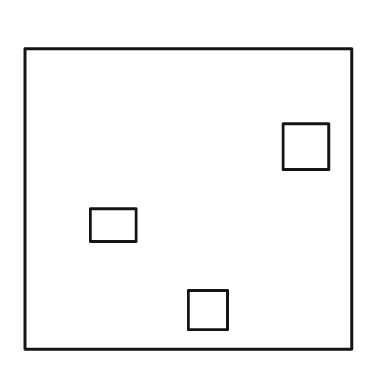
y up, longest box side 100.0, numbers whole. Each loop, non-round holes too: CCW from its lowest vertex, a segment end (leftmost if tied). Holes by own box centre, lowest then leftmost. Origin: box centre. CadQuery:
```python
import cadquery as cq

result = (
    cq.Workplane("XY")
    .moveTo(-50.0, -46.0)
    .lineTo(50.0, -46.0)
    .lineTo(50.0, 46.0)
    .lineTo(-50.0, 46.0)
    .close()
    .moveTo(0.0, -40.0)
    .lineTo(12.0, -40.0)
    .lineTo(12.0, -28.0)
    .lineTo(0.0, -28.0)
    .close()
    .moveTo(-30.0, -13.0)
    .lineTo(-16.0, -13.0)
    .lineTo(-16.0, -3.0)
    .lineTo(-30.0, -3.0)
    .close()
    .moveTo(29.0, 9.0)
    .lineTo(43.0, 9.0)
    .lineTo(43.0, 23.0)
    .lineTo(29.0, 23.0)
    .close()
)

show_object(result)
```